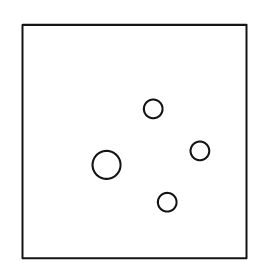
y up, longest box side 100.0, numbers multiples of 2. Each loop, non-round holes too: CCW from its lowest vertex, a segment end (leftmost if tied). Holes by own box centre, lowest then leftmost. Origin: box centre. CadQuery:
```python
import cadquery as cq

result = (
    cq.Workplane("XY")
    .moveTo(-48.0, -50.0)
    .lineTo(48.0, -50.0)
    .lineTo(48.0, 50.0)
    .lineTo(-48.0, 50.0)
    .close()
    .moveTo(14.0, -26.0)
    .circle(4.0)
    .moveTo(-12.0, -10.0)
    .circle(6.0)
    .moveTo(28.0, -4.0)
    .circle(4.0)
    .moveTo(8.0, 14.0)
    .circle(4.0)
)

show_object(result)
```